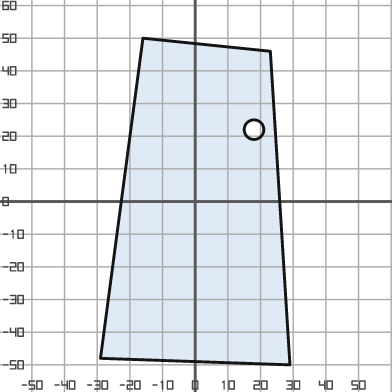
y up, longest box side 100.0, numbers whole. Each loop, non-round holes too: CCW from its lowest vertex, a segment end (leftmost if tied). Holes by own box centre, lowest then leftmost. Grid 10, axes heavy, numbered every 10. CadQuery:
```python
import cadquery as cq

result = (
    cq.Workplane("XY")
    .moveTo(29.0, -50.0)
    .lineTo(23.0, 46.0)
    .lineTo(-16.0, 50.0)
    .lineTo(-29.0, -48.0)
    .close()
    .moveTo(18.0, 22.0)
    .circle(3.0)
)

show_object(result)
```